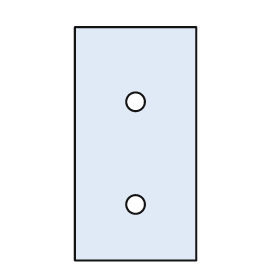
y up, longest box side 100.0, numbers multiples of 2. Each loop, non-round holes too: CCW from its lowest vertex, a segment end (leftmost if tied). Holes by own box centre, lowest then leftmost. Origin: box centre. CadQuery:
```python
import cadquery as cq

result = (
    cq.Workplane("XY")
    .moveTo(-26.0, -50.0)
    .lineTo(26.0, -50.0)
    .lineTo(26.0, 50.0)
    .lineTo(-26.0, 50.0)
    .close()
    .moveTo(0.0, -26.0)
    .circle(4.0)
    .moveTo(0.0, 18.0)
    .circle(4.0)
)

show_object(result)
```